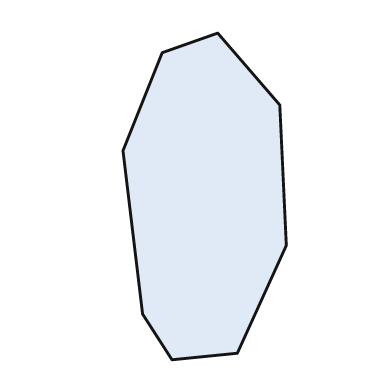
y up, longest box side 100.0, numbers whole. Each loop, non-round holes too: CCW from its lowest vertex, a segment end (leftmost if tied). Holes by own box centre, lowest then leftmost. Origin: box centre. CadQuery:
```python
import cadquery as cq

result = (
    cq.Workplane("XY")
    .moveTo(-10.0, -50.0)
    .lineTo(10.0, -48.0)
    .lineTo(25.0, -15.0)
    .lineTo(23.0, 28.0)
    .lineTo(4.0, 50.0)
    .lineTo(-13.0, 44.0)
    .lineTo(-25.0, 14.0)
    .lineTo(-19.0, -36.0)
    .close()
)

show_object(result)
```